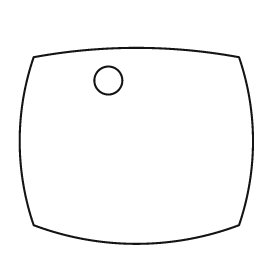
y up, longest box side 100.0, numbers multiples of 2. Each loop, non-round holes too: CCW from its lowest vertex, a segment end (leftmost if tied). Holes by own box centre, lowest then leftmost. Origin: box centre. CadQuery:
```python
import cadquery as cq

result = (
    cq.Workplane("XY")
    .moveTo(-44.0, -34.0)
    .threePointArc((0.0, -42.0), (44.0, -34.0))
    .threePointArc((50.0, 2.0), (44.0, 38.0))
    .threePointArc((0.0, 42.0), (-44.0, 38.0))
    .threePointArc((-50.0, 2.0), (-44.0, -34.0))
    .close()
    .moveTo(-12.0, 28.0)
    .circle(6.0)
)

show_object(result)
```